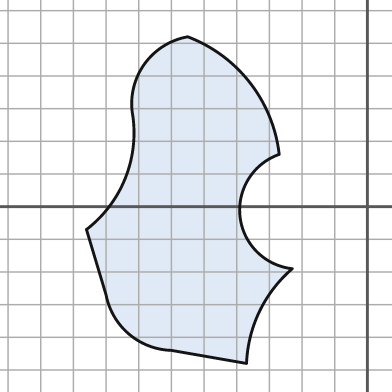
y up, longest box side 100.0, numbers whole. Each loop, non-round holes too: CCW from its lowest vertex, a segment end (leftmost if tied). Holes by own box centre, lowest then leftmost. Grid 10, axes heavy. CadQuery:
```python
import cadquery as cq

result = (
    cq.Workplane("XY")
    .moveTo(-37.0, -48.0)
    .threePointArc((-33.0, -32.0), (-23.0, -19.0))
    .threePointArc((-39.0, -3.0), (-27.0, 16.0))
    .threePointArc((-36.0, 38.0), (-55.0, 52.0))
    .threePointArc((-68.0, 44.0), (-72.0, 29.0))
    .threePointArc((-74.0, 9.0), (-86.0, -7.0))
    .lineTo(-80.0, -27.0)
    .threePointArc((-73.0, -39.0), (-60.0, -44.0))
    .close()
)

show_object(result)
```